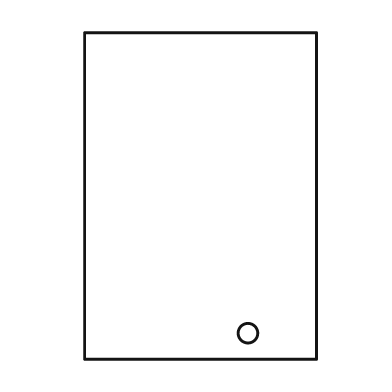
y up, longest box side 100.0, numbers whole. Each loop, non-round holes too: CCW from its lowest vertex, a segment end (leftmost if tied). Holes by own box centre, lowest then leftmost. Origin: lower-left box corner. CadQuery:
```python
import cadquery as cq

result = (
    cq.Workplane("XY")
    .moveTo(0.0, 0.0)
    .lineTo(71.0, 0.0)
    .lineTo(71.0, 100.0)
    .lineTo(0.0, 100.0)
    .close()
    .moveTo(50.0, 8.0)
    .circle(3.0)
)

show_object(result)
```